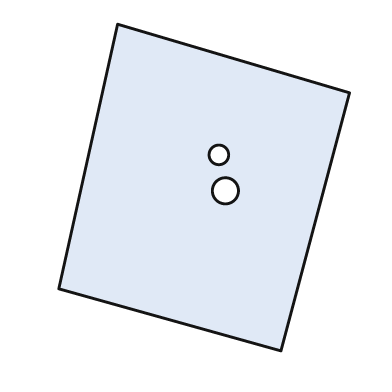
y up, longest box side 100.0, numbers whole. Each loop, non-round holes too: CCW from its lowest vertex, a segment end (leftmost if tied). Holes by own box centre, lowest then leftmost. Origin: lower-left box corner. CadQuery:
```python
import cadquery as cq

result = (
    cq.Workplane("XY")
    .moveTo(68.0, 0.0)
    .lineTo(89.0, 79.0)
    .lineTo(18.0, 100.0)
    .lineTo(0.0, 19.0)
    .close()
    .moveTo(51.0, 49.0)
    .circle(4.0)
    .moveTo(49.0, 60.0)
    .circle(3.0)
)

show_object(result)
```